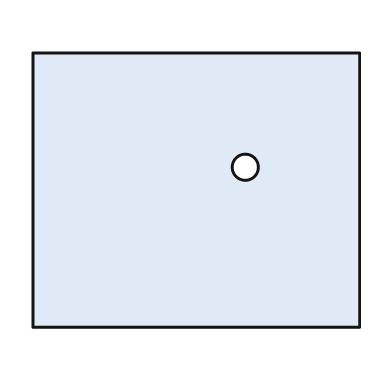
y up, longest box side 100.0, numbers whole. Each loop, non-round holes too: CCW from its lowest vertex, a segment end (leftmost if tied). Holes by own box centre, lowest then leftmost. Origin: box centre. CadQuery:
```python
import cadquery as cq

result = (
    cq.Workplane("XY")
    .moveTo(-50.0, -42.0)
    .lineTo(50.0, -42.0)
    .lineTo(50.0, 42.0)
    .lineTo(-50.0, 42.0)
    .close()
    .moveTo(15.0, 7.0)
    .circle(4.0)
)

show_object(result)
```